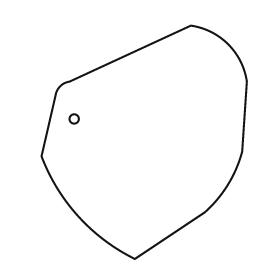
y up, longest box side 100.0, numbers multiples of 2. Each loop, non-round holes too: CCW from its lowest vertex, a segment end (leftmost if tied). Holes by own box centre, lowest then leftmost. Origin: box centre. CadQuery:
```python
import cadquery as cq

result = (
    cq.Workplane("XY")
    .moveTo(-4.0, -50.0)
    .lineTo(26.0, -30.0)
    .threePointArc((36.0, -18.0), (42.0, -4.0))
    .lineTo(44.0, 26.0)
    .threePointArc((36.0, 42.0), (20.0, 50.0))
    .lineTo(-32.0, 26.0)
    .threePointArc((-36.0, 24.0), (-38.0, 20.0))
    .lineTo(-44.0, -6.0)
    .threePointArc((-28.0, -32.0), (-4.0, -50.0))
    .close()
    .moveTo(-30.0, 10.0)
    .circle(2.0)
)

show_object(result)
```